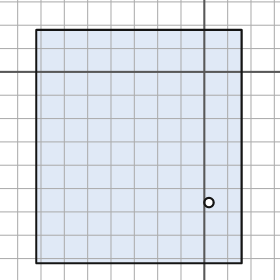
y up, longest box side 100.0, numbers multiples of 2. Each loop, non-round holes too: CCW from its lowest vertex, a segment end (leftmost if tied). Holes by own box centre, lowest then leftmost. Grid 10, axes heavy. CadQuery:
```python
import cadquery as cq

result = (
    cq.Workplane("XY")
    .moveTo(-72.0, -82.0)
    .lineTo(16.0, -82.0)
    .lineTo(16.0, 18.0)
    .lineTo(-72.0, 18.0)
    .close()
    .moveTo(2.0, -56.0)
    .circle(2.0)
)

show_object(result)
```